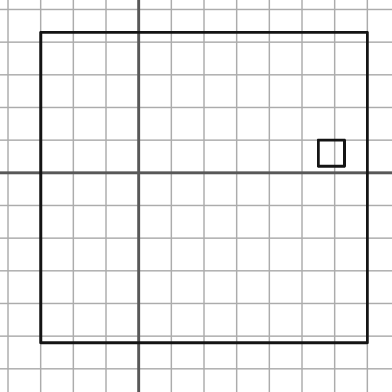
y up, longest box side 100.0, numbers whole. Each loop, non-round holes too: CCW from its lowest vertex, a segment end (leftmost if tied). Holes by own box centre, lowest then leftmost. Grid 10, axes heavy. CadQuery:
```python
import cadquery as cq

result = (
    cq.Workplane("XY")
    .moveTo(-30.0, -52.0)
    .lineTo(70.0, -52.0)
    .lineTo(70.0, 43.0)
    .lineTo(-30.0, 43.0)
    .close()
    .moveTo(55.0, 2.0)
    .lineTo(63.0, 2.0)
    .lineTo(63.0, 10.0)
    .lineTo(55.0, 10.0)
    .close()
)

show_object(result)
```